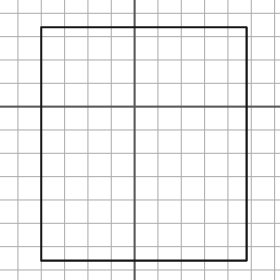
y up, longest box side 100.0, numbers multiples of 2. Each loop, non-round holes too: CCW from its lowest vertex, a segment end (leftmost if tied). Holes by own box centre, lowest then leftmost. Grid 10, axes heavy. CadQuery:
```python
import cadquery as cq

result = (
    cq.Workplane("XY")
    .moveTo(-40.0, -66.0)
    .lineTo(48.0, -66.0)
    .lineTo(48.0, 34.0)
    .lineTo(-40.0, 34.0)
    .close()
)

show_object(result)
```